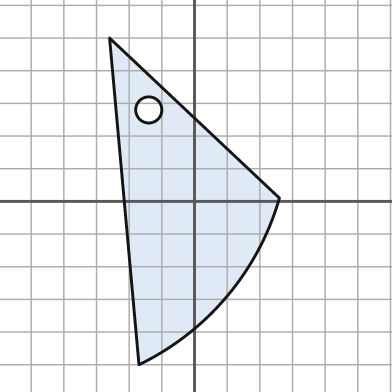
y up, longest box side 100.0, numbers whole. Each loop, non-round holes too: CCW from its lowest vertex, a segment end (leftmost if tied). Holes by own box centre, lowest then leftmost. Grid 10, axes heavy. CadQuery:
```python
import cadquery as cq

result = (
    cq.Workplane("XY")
    .moveTo(-17.0, -50.0)
    .threePointArc((10.0, -29.0), (26.0, 1.0))
    .lineTo(-26.0, 50.0)
    .close()
    .moveTo(-14.0, 28.0)
    .circle(4.0)
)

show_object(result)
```